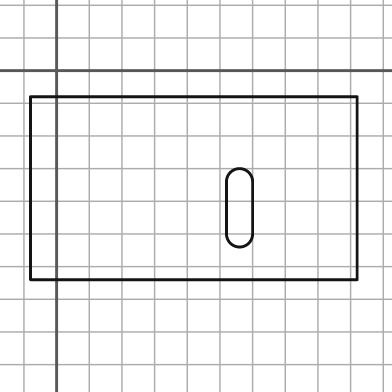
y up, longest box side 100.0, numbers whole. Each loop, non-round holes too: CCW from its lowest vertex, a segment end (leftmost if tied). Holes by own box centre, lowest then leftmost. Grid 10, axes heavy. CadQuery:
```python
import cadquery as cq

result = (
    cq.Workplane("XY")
    .moveTo(-8.0, -64.0)
    .lineTo(92.0, -64.0)
    .lineTo(92.0, -8.0)
    .lineTo(-8.0, -8.0)
    .close()
    .moveTo(52.0, -50.0)
    .threePointArc((56.0, -54.0), (60.0, -50.0))
    .lineTo(60.0, -34.0)
    .threePointArc((56.0, -30.0), (52.0, -34.0))
    .close()
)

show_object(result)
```